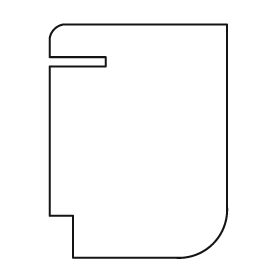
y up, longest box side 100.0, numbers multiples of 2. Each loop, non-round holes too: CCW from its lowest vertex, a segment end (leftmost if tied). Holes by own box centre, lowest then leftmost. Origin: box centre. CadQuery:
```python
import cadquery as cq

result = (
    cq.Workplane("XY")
    .moveTo(-28.0, -50.0)
    .lineTo(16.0, -50.0)
    .threePointArc((32.0, -44.0), (38.0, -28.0))
    .lineTo(38.0, 50.0)
    .lineTo(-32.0, 50.0)
    .threePointArc((-36.0, 48.0), (-38.0, 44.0))
    .lineTo(-38.0, 36.0)
    .lineTo(-14.0, 36.0)
    .lineTo(-14.0, 32.0)
    .lineTo(-38.0, 32.0)
    .lineTo(-38.0, -32.0)
    .lineTo(-28.0, -32.0)
    .close()
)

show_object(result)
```